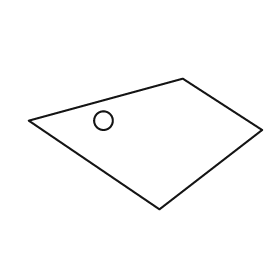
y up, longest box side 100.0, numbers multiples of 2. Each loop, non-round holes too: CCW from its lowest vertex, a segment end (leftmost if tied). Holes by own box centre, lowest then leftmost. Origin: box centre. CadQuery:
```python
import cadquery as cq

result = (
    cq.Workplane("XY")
    .moveTo(6.0, -28.0)
    .lineTo(50.0, 6.0)
    .lineTo(16.0, 28.0)
    .lineTo(-50.0, 10.0)
    .close()
    .moveTo(-18.0, 10.0)
    .circle(4.0)
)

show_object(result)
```